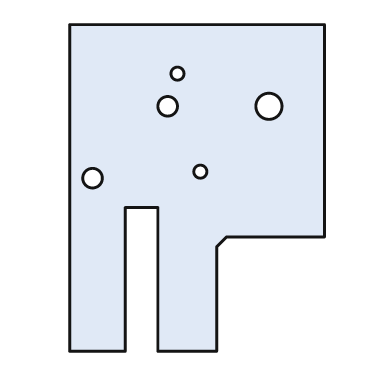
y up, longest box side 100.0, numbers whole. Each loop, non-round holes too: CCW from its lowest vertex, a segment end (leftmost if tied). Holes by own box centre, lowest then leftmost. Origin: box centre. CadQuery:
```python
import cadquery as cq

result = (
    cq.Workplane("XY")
    .moveTo(-39.0, -50.0)
    .lineTo(-22.0, -50.0)
    .lineTo(-22.0, -6.0)
    .lineTo(-12.0, -6.0)
    .lineTo(-12.0, -50.0)
    .lineTo(6.0, -50.0)
    .lineTo(6.0, -18.0)
    .lineTo(9.0, -15.0)
    .lineTo(39.0, -15.0)
    .lineTo(39.0, 50.0)
    .lineTo(-39.0, 50.0)
    .close()
    .moveTo(-32.0, 3.0)
    .circle(3.0)
    .moveTo(1.0, 5.0)
    .circle(2.0)
    .moveTo(-9.0, 25.0)
    .circle(3.0)
    .moveTo(22.0, 25.0)
    .circle(4.0)
    .moveTo(-6.0, 35.0)
    .circle(2.0)
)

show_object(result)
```